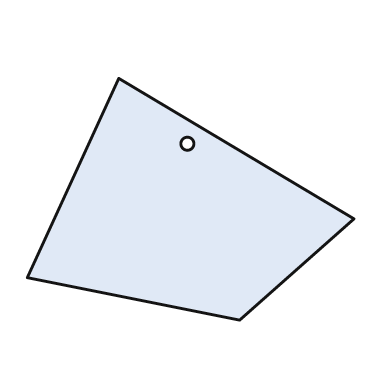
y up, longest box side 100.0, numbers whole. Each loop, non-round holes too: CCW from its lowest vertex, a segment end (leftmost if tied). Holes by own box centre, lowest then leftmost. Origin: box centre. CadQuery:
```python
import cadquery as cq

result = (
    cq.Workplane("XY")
    .moveTo(15.0, -37.0)
    .lineTo(50.0, -6.0)
    .lineTo(-22.0, 37.0)
    .lineTo(-50.0, -24.0)
    .close()
    .moveTo(-1.0, 17.0)
    .circle(2.0)
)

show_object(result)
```